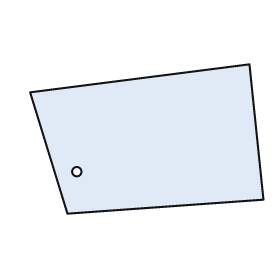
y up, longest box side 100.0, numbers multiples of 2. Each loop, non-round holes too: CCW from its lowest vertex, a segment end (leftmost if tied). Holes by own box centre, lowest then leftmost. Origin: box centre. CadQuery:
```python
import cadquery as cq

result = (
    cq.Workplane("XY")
    .moveTo(-34.0, -32.0)
    .lineTo(50.0, -26.0)
    .lineTo(44.0, 32.0)
    .lineTo(-50.0, 20.0)
    .close()
    .moveTo(-30.0, -14.0)
    .circle(2.0)
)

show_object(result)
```